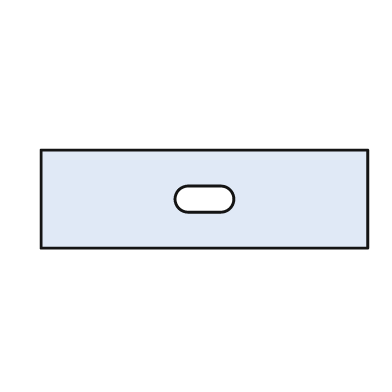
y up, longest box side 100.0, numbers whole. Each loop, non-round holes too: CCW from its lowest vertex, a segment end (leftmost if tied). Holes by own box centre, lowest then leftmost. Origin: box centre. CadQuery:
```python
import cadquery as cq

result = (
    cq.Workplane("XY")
    .moveTo(-50.0, -15.0)
    .lineTo(50.0, -15.0)
    .lineTo(50.0, 15.0)
    .lineTo(-50.0, 15.0)
    .close()
    .moveTo(-5.0, -4.0)
    .lineTo(5.0, -4.0)
    .threePointArc((9.0, 0.0), (5.0, 4.0))
    .lineTo(-5.0, 4.0)
    .threePointArc((-9.0, 0.0), (-5.0, -4.0))
    .close()
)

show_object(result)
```